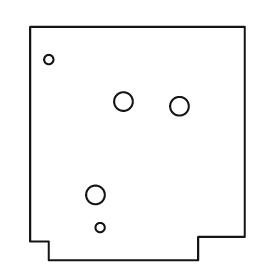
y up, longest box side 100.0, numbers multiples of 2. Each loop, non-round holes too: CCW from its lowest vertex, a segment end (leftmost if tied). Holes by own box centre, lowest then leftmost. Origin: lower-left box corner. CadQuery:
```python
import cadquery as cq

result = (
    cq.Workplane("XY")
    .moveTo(8.0, 0.0)
    .lineTo(72.0, 0.0)
    .lineTo(72.0, 10.0)
    .lineTo(92.0, 10.0)
    .lineTo(92.0, 100.0)
    .lineTo(0.0, 100.0)
    .lineTo(0.0, 8.0)
    .lineTo(8.0, 8.0)
    .close()
    .moveTo(30.0, 14.0)
    .circle(2.0)
    .moveTo(28.0, 28.0)
    .circle(4.0)
    .moveTo(64.0, 66.0)
    .circle(4.0)
    .moveTo(40.0, 68.0)
    .circle(4.0)
    .moveTo(8.0, 86.0)
    .circle(2.0)
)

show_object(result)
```